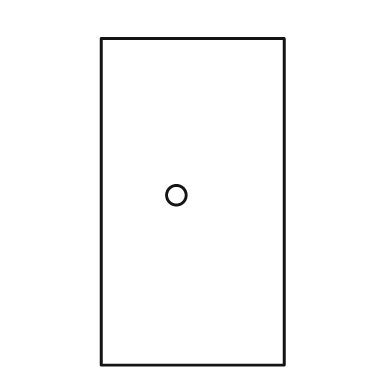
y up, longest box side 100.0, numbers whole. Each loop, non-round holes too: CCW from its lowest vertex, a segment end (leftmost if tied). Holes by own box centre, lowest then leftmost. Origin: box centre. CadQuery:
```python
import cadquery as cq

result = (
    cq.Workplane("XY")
    .moveTo(-28.0, -50.0)
    .lineTo(28.0, -50.0)
    .lineTo(28.0, 50.0)
    .lineTo(-28.0, 50.0)
    .close()
    .moveTo(-5.0, 2.0)
    .circle(3.0)
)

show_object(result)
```